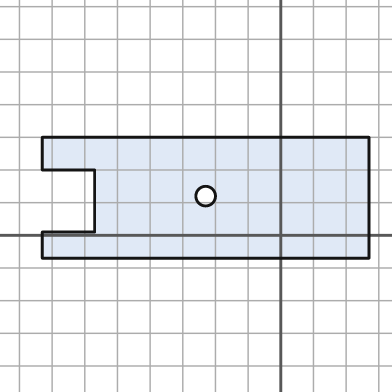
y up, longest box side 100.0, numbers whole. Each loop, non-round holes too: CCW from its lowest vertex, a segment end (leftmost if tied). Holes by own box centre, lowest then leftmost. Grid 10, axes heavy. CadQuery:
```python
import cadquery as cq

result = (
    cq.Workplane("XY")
    .moveTo(-73.0, -7.0)
    .lineTo(27.0, -7.0)
    .lineTo(27.0, 30.0)
    .lineTo(-73.0, 30.0)
    .lineTo(-73.0, 20.0)
    .lineTo(-57.0, 20.0)
    .lineTo(-57.0, 1.0)
    .lineTo(-73.0, 1.0)
    .close()
    .moveTo(-23.0, 12.0)
    .circle(3.0)
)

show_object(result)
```